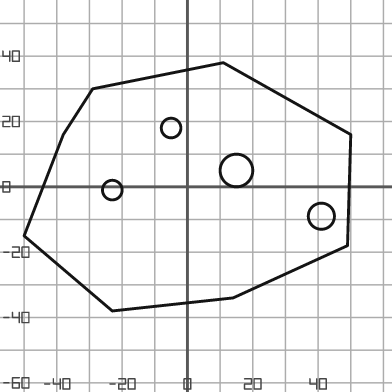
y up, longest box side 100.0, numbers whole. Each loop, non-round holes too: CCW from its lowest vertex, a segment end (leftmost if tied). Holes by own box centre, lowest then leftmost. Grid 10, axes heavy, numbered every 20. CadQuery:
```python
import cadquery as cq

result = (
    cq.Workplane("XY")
    .moveTo(-23.0, -38.0)
    .lineTo(14.0, -34.0)
    .lineTo(49.0, -18.0)
    .lineTo(50.0, 16.0)
    .lineTo(11.0, 38.0)
    .lineTo(-29.0, 30.0)
    .lineTo(-38.0, 16.0)
    .lineTo(-50.0, -15.0)
    .close()
    .moveTo(41.0, -9.0)
    .circle(4.0)
    .moveTo(-23.0, -1.0)
    .circle(3.0)
    .moveTo(15.0, 5.0)
    .circle(5.0)
    .moveTo(-5.0, 18.0)
    .circle(3.0)
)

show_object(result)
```